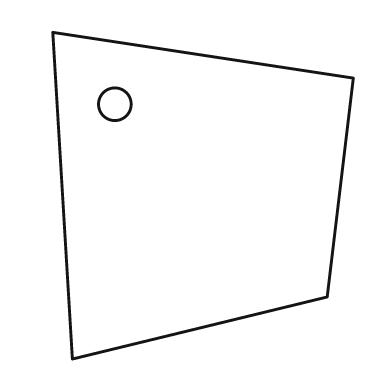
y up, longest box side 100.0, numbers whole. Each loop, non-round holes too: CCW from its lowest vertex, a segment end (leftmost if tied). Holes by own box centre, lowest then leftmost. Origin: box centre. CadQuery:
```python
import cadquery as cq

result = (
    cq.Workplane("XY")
    .moveTo(-40.0, -50.0)
    .lineTo(38.0, -31.0)
    .lineTo(46.0, 36.0)
    .lineTo(-46.0, 50.0)
    .close()
    .moveTo(-27.0, 28.0)
    .circle(5.0)
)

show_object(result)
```